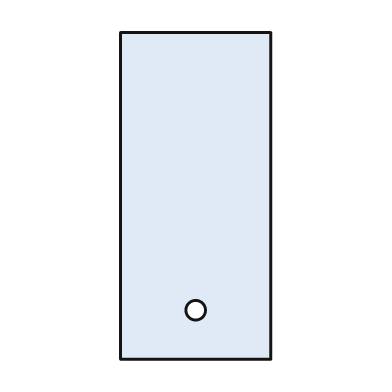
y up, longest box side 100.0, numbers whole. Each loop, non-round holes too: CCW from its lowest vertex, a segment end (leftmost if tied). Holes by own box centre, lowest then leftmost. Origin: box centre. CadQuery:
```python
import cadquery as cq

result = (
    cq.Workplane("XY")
    .moveTo(-23.0, -50.0)
    .lineTo(23.0, -50.0)
    .lineTo(23.0, 50.0)
    .lineTo(-23.0, 50.0)
    .close()
    .moveTo(0.0, -35.0)
    .circle(3.0)
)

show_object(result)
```